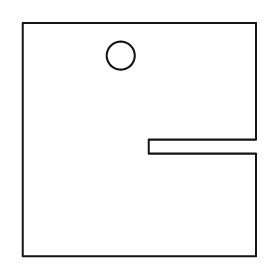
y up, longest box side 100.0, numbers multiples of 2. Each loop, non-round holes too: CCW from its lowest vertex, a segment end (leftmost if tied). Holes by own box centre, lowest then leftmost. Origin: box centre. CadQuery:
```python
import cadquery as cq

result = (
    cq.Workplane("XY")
    .moveTo(-50.0, -50.0)
    .lineTo(50.0, -50.0)
    .lineTo(50.0, -6.0)
    .lineTo(4.0, -6.0)
    .lineTo(4.0, 0.0)
    .lineTo(50.0, 0.0)
    .lineTo(50.0, 50.0)
    .lineTo(-50.0, 50.0)
    .close()
    .moveTo(-8.0, 36.0)
    .circle(6.0)
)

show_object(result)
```